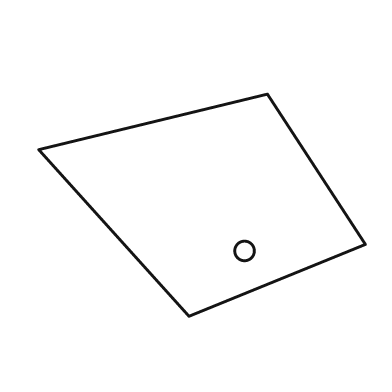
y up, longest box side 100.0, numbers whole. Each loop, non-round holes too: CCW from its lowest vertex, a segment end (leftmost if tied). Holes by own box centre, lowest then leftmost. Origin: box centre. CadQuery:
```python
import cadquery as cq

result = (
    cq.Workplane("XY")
    .moveTo(-4.0, -34.0)
    .lineTo(50.0, -12.0)
    .lineTo(20.0, 34.0)
    .lineTo(-50.0, 17.0)
    .close()
    .moveTo(13.0, -14.0)
    .circle(3.0)
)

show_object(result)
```